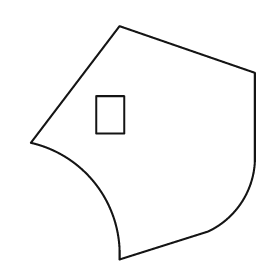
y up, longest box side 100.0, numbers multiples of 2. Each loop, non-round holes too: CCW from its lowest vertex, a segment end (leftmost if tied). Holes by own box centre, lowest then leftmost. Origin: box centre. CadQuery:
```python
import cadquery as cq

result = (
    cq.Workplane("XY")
    .moveTo(-10.0, -50.0)
    .lineTo(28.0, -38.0)
    .threePointArc((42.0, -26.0), (48.0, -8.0))
    .lineTo(48.0, 30.0)
    .lineTo(-10.0, 50.0)
    .lineTo(-48.0, 0.0)
    .threePointArc((-20.0, -18.0), (-10.0, -50.0))
    .close()
    .moveTo(-20.0, 4.0)
    .lineTo(-8.0, 4.0)
    .lineTo(-8.0, 20.0)
    .lineTo(-20.0, 20.0)
    .close()
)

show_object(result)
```